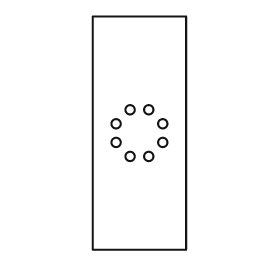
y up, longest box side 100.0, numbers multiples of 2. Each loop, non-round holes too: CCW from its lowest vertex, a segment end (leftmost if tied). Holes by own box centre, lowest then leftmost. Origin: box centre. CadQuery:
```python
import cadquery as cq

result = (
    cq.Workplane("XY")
    .moveTo(-20.0, -50.0)
    .lineTo(20.0, -50.0)
    .lineTo(20.0, 50.0)
    .lineTo(-20.0, 50.0)
    .close()
    .moveTo(-4.0, -10.0)
    .circle(2.0)
    .moveTo(4.0, -10.0)
    .circle(2.0)
    .moveTo(-10.0, -4.0)
    .circle(2.0)
    .moveTo(10.0, -4.0)
    .circle(2.0)
    .moveTo(-10.0, 4.0)
    .circle(2.0)
    .moveTo(10.0, 4.0)
    .circle(2.0)
    .moveTo(-4.0, 10.0)
    .circle(2.0)
    .moveTo(4.0, 10.0)
    .circle(2.0)
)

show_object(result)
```